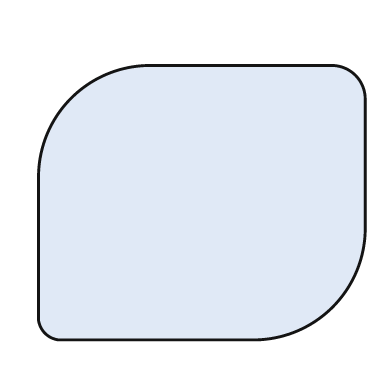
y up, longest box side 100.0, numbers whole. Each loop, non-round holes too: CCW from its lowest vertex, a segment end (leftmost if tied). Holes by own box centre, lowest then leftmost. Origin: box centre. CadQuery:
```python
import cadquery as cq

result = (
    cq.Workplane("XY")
    .moveTo(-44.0, -42.0)
    .lineTo(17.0, -42.0)
    .threePointArc((40.0, -32.0), (50.0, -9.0))
    .lineTo(50.0, 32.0)
    .threePointArc((47.0, 39.0), (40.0, 42.0))
    .lineTo(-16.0, 42.0)
    .threePointArc((-40.0, 32.0), (-50.0, 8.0))
    .lineTo(-50.0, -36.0)
    .threePointArc((-48.0, -40.0), (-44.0, -42.0))
    .close()
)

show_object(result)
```